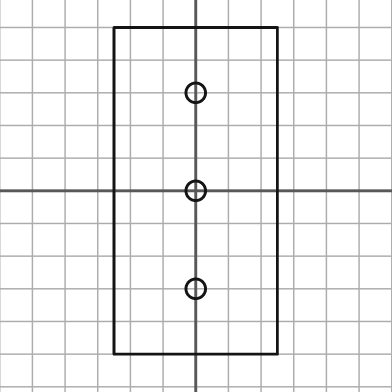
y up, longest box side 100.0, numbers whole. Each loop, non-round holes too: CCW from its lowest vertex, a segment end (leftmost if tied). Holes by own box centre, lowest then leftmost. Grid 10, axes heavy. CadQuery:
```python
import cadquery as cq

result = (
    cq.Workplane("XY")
    .moveTo(-25.0, -50.0)
    .lineTo(25.0, -50.0)
    .lineTo(25.0, 50.0)
    .lineTo(-25.0, 50.0)
    .close()
    .moveTo(0.0, -30.0)
    .circle(3.0)
    .moveTo(0.0, 0.0)
    .circle(3.0)
    .moveTo(0.0, 30.0)
    .circle(3.0)
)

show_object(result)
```